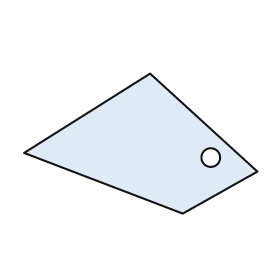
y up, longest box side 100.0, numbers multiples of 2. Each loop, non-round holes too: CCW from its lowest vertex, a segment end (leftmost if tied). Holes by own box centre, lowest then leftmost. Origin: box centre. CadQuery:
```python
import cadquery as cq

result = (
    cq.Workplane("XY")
    .moveTo(18.0, -30.0)
    .lineTo(50.0, -12.0)
    .lineTo(4.0, 30.0)
    .lineTo(-50.0, -4.0)
    .close()
    .moveTo(30.0, -6.0)
    .circle(4.0)
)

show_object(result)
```